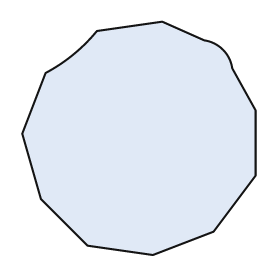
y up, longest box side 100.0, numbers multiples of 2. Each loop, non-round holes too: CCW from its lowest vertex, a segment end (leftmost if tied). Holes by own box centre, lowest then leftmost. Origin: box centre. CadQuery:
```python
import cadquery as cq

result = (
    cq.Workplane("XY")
    .moveTo(6.0, -50.0)
    .lineTo(32.0, -40.0)
    .lineTo(50.0, -16.0)
    .lineTo(50.0, 12.0)
    .lineTo(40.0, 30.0)
    .threePointArc((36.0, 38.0), (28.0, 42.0))
    .lineTo(10.0, 50.0)
    .lineTo(-18.0, 46.0)
    .threePointArc((-28.0, 36.0), (-40.0, 28.0))
    .lineTo(-50.0, 2.0)
    .lineTo(-42.0, -26.0)
    .lineTo(-22.0, -46.0)
    .close()
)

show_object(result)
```